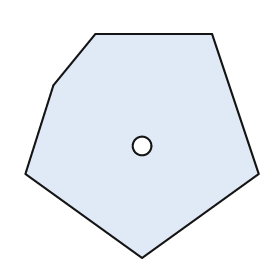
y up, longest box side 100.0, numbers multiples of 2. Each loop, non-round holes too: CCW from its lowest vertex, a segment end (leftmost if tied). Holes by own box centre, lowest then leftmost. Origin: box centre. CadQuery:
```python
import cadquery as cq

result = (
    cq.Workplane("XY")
    .moveTo(0.0, -48.0)
    .lineTo(50.0, -12.0)
    .lineTo(30.0, 48.0)
    .lineTo(-20.0, 48.0)
    .lineTo(-38.0, 26.0)
    .lineTo(-50.0, -12.0)
    .close()
    .moveTo(0.0, 0.0)
    .circle(4.0)
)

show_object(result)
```